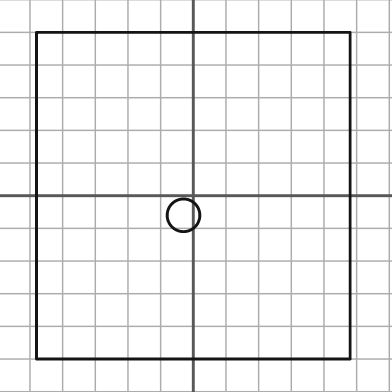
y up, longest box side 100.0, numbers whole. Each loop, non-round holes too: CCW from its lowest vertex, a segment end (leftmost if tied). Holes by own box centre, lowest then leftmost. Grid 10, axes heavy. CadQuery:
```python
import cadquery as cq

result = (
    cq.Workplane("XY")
    .moveTo(-48.0, -50.0)
    .lineTo(48.0, -50.0)
    .lineTo(48.0, 50.0)
    .lineTo(-48.0, 50.0)
    .close()
    .moveTo(-3.0, -6.0)
    .circle(5.0)
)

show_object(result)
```